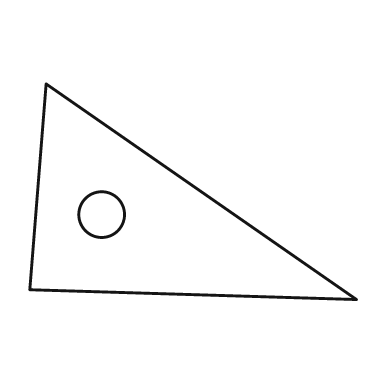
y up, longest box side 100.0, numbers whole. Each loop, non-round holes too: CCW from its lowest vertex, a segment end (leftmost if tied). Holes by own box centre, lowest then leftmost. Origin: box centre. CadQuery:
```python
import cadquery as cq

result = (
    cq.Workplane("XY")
    .moveTo(50.0, -33.0)
    .lineTo(-45.0, 33.0)
    .lineTo(-50.0, -30.0)
    .close()
    .moveTo(-28.0, -7.0)
    .circle(7.0)
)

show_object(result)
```